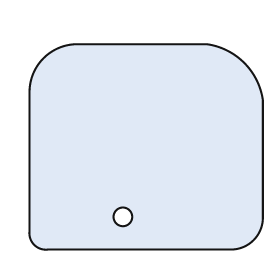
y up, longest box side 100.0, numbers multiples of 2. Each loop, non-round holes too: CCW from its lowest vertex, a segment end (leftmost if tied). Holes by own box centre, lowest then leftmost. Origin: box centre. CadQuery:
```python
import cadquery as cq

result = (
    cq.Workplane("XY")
    .moveTo(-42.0, -44.0)
    .lineTo(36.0, -44.0)
    .threePointArc((46.0, -40.0), (50.0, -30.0))
    .lineTo(50.0, 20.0)
    .threePointArc((42.0, 36.0), (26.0, 44.0))
    .lineTo(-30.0, 44.0)
    .threePointArc((-44.0, 38.0), (-50.0, 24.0))
    .lineTo(-50.0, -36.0)
    .threePointArc((-48.0, -42.0), (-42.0, -44.0))
    .close()
    .moveTo(-10.0, -30.0)
    .circle(4.0)
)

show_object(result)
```